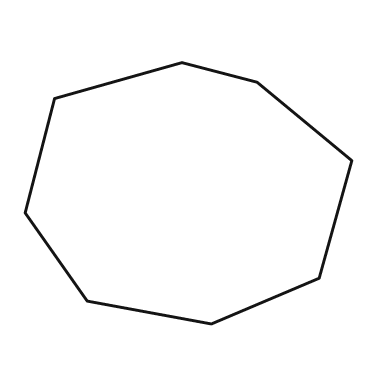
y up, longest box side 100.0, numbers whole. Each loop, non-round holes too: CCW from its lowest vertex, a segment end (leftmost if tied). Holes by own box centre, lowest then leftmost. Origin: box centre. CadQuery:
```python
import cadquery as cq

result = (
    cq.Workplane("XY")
    .moveTo(7.0, -40.0)
    .lineTo(40.0, -26.0)
    .lineTo(50.0, 10.0)
    .lineTo(21.0, 34.0)
    .lineTo(-2.0, 40.0)
    .lineTo(-41.0, 29.0)
    .lineTo(-50.0, -6.0)
    .lineTo(-31.0, -33.0)
    .close()
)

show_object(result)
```